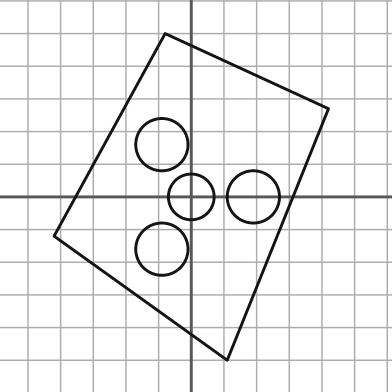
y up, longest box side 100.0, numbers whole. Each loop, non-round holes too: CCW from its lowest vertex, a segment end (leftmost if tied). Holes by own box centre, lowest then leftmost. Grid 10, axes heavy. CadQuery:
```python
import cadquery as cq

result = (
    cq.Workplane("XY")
    .moveTo(11.0, -50.0)
    .lineTo(42.0, 27.0)
    .lineTo(-8.0, 50.0)
    .lineTo(-42.0, -12.0)
    .close()
    .moveTo(-9.0, -16.0)
    .circle(8.0)
    .moveTo(0.0, 0.0)
    .circle(7.0)
    .moveTo(19.0, 0.0)
    .circle(8.0)
    .moveTo(-9.0, 16.0)
    .circle(8.0)
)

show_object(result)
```